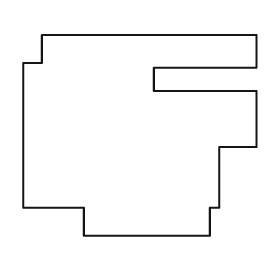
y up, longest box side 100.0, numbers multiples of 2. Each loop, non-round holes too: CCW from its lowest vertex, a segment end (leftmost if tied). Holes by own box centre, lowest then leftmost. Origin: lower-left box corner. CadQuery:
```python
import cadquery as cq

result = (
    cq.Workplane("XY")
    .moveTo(26.0, 0.0)
    .lineTo(80.0, 0.0)
    .lineTo(80.0, 12.0)
    .lineTo(84.0, 12.0)
    .lineTo(84.0, 38.0)
    .lineTo(100.0, 38.0)
    .lineTo(100.0, 62.0)
    .lineTo(56.0, 62.0)
    .lineTo(56.0, 72.0)
    .lineTo(100.0, 72.0)
    .lineTo(100.0, 86.0)
    .lineTo(8.0, 86.0)
    .lineTo(8.0, 74.0)
    .lineTo(0.0, 74.0)
    .lineTo(0.0, 12.0)
    .lineTo(26.0, 12.0)
    .close()
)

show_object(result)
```